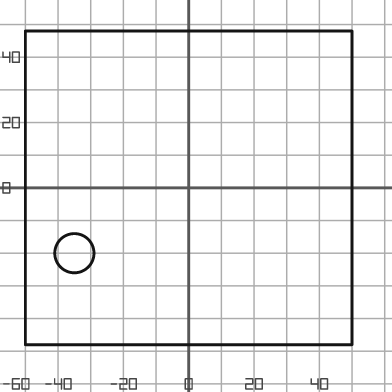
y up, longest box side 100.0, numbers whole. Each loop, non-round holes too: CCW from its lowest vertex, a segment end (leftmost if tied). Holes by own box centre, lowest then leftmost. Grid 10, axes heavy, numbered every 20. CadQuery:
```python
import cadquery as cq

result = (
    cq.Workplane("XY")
    .moveTo(-50.0, -48.0)
    .lineTo(50.0, -48.0)
    .lineTo(50.0, 48.0)
    .lineTo(-50.0, 48.0)
    .close()
    .moveTo(-35.0, -20.0)
    .circle(6.0)
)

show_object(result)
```